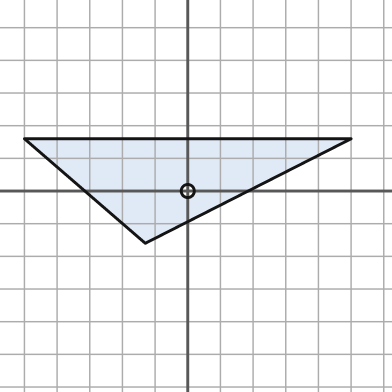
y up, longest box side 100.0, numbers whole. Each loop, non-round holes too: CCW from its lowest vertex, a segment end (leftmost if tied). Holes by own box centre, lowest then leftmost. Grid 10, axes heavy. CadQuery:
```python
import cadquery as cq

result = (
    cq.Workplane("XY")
    .moveTo(-13.0, -16.0)
    .lineTo(50.0, 16.0)
    .lineTo(-50.0, 16.0)
    .close()
    .moveTo(0.0, 0.0)
    .circle(2.0)
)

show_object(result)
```